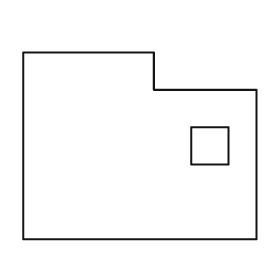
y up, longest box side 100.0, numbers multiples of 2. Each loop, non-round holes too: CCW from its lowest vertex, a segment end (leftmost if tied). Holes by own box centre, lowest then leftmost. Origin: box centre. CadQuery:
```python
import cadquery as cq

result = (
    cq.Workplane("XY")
    .moveTo(-50.0, -40.0)
    .lineTo(50.0, -40.0)
    .lineTo(50.0, 24.0)
    .lineTo(6.0, 24.0)
    .lineTo(6.0, 40.0)
    .lineTo(-50.0, 40.0)
    .close()
    .moveTo(22.0, -8.0)
    .lineTo(38.0, -8.0)
    .lineTo(38.0, 8.0)
    .lineTo(22.0, 8.0)
    .close()
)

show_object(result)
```